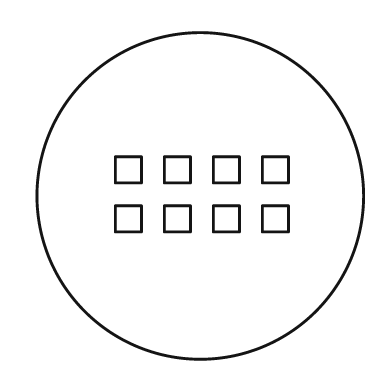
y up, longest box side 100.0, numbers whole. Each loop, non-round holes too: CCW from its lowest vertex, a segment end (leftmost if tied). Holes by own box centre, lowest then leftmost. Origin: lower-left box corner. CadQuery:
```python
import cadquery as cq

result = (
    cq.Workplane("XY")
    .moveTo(50.0, 50.0)
    .circle(50.0)
    .moveTo(24.0, 39.0)
    .lineTo(32.0, 39.0)
    .lineTo(32.0, 47.0)
    .lineTo(24.0, 47.0)
    .close()
    .moveTo(39.0, 39.0)
    .lineTo(47.0, 39.0)
    .lineTo(47.0, 47.0)
    .lineTo(39.0, 47.0)
    .close()
    .moveTo(54.0, 39.0)
    .lineTo(62.0, 39.0)
    .lineTo(62.0, 47.0)
    .lineTo(54.0, 47.0)
    .close()
    .moveTo(69.0, 39.0)
    .lineTo(77.0, 39.0)
    .lineTo(77.0, 47.0)
    .lineTo(69.0, 47.0)
    .close()
    .moveTo(24.0, 54.0)
    .lineTo(32.0, 54.0)
    .lineTo(32.0, 62.0)
    .lineTo(24.0, 62.0)
    .close()
    .moveTo(39.0, 54.0)
    .lineTo(47.0, 54.0)
    .lineTo(47.0, 62.0)
    .lineTo(39.0, 62.0)
    .close()
    .moveTo(54.0, 54.0)
    .lineTo(62.0, 54.0)
    .lineTo(62.0, 62.0)
    .lineTo(54.0, 62.0)
    .close()
    .moveTo(69.0, 54.0)
    .lineTo(77.0, 54.0)
    .lineTo(77.0, 62.0)
    .lineTo(69.0, 62.0)
    .close()
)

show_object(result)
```